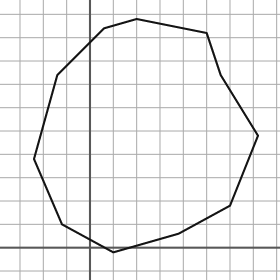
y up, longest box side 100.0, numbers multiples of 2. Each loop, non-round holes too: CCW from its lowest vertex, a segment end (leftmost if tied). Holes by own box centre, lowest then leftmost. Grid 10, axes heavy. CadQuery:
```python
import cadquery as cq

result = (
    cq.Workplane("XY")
    .moveTo(10.0, -2.0)
    .lineTo(38.0, 6.0)
    .lineTo(60.0, 18.0)
    .lineTo(72.0, 48.0)
    .lineTo(56.0, 74.0)
    .lineTo(50.0, 92.0)
    .lineTo(20.0, 98.0)
    .lineTo(6.0, 94.0)
    .lineTo(-14.0, 74.0)
    .lineTo(-24.0, 38.0)
    .lineTo(-12.0, 10.0)
    .close()
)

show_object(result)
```